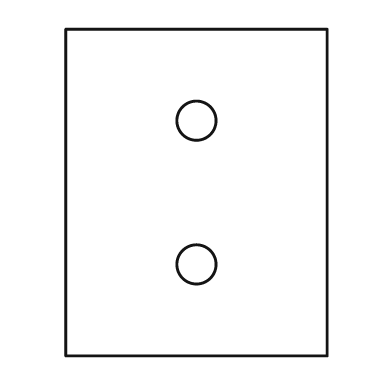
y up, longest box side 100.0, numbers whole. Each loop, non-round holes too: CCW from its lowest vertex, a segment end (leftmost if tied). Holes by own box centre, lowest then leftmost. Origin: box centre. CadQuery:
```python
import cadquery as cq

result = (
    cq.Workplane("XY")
    .moveTo(-40.0, -50.0)
    .lineTo(40.0, -50.0)
    .lineTo(40.0, 50.0)
    .lineTo(-40.0, 50.0)
    .close()
    .moveTo(0.0, -22.0)
    .circle(6.0)
    .moveTo(0.0, 22.0)
    .circle(6.0)
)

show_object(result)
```